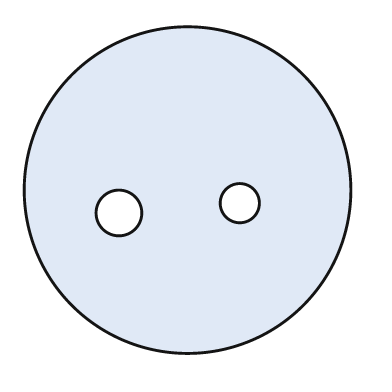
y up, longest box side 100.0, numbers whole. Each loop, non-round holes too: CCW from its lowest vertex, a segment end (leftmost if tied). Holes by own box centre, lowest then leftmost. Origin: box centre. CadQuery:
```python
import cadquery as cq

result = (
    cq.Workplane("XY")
    .moveTo(0.0, 0.0)
    .circle(50.0)
    .moveTo(-21.0, -7.0)
    .circle(7.0)
    .moveTo(16.0, -4.0)
    .circle(6.0)
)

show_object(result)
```